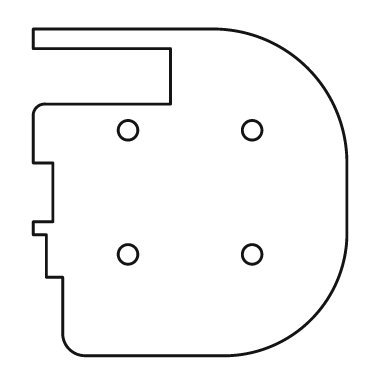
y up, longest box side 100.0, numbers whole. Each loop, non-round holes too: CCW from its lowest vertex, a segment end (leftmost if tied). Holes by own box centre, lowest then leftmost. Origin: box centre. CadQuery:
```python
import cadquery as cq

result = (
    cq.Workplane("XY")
    .moveTo(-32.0, -50.0)
    .lineTo(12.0, -50.0)
    .threePointArc((37.0, -39.0), (48.0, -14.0))
    .lineTo(48.0, 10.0)
    .threePointArc((36.0, 38.0), (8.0, 50.0))
    .lineTo(-48.0, 50.0)
    .lineTo(-48.0, 44.0)
    .lineTo(-6.0, 44.0)
    .lineTo(-6.0, 27.0)
    .lineTo(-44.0, 27.0)
    .threePointArc((-47.0, 26.0), (-48.0, 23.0))
    .lineTo(-48.0, 9.0)
    .lineTo(-42.0, 9.0)
    .lineTo(-42.0, -9.0)
    .lineTo(-48.0, -9.0)
    .lineTo(-48.0, -13.0)
    .lineTo(-44.0, -13.0)
    .lineTo(-44.0, -26.0)
    .lineTo(-39.0, -26.0)
    .lineTo(-39.0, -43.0)
    .threePointArc((-37.0, -48.0), (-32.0, -50.0))
    .close()
    .moveTo(-19.0, -19.0)
    .circle(3.0)
    .moveTo(19.0, -19.0)
    .circle(3.0)
    .moveTo(-19.0, 19.0)
    .circle(3.0)
    .moveTo(19.0, 19.0)
    .circle(3.0)
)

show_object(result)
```